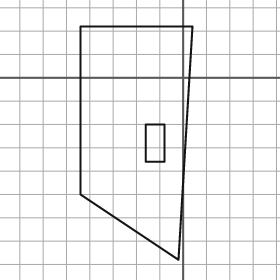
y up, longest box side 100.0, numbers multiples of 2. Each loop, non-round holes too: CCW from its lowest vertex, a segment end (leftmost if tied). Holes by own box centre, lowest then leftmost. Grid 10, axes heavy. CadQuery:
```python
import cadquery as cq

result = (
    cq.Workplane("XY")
    .moveTo(-2.0, -78.0)
    .lineTo(4.0, 22.0)
    .lineTo(-44.0, 22.0)
    .lineTo(-44.0, -50.0)
    .close()
    .moveTo(-16.0, -36.0)
    .lineTo(-8.0, -36.0)
    .lineTo(-8.0, -20.0)
    .lineTo(-16.0, -20.0)
    .close()
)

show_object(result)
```